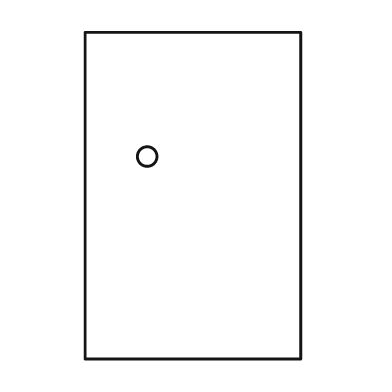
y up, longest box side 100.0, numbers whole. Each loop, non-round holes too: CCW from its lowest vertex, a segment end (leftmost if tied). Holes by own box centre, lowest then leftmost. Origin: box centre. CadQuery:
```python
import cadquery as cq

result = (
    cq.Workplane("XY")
    .moveTo(-33.0, -50.0)
    .lineTo(33.0, -50.0)
    .lineTo(33.0, 50.0)
    .lineTo(-33.0, 50.0)
    .close()
    .moveTo(-14.0, 12.0)
    .circle(3.0)
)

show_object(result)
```